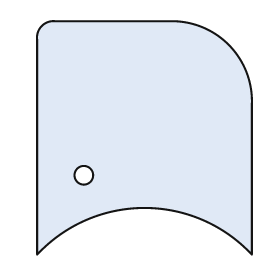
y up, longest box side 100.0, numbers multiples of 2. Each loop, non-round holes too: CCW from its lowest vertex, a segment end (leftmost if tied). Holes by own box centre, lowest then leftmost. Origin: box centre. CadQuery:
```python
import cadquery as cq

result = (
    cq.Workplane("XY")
    .moveTo(-46.0, -50.0)
    .threePointArc((0.0, -30.0), (46.0, -50.0))
    .lineTo(46.0, 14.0)
    .threePointArc((36.0, 40.0), (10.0, 50.0))
    .lineTo(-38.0, 50.0)
    .threePointArc((-44.0, 48.0), (-46.0, 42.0))
    .close()
    .moveTo(-26.0, -16.0)
    .circle(4.0)
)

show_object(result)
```